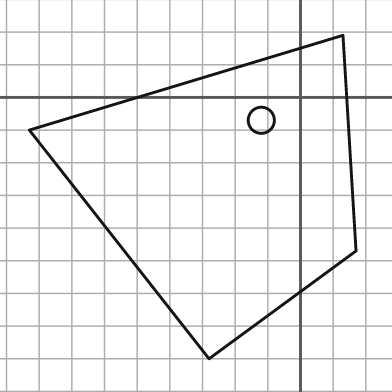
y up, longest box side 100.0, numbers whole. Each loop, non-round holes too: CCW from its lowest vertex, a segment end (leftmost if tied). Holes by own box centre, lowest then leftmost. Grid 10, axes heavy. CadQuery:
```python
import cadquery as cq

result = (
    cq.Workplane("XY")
    .moveTo(-28.0, -80.0)
    .lineTo(17.0, -47.0)
    .lineTo(13.0, 19.0)
    .lineTo(-83.0, -10.0)
    .close()
    .moveTo(-12.0, -7.0)
    .circle(4.0)
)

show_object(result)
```